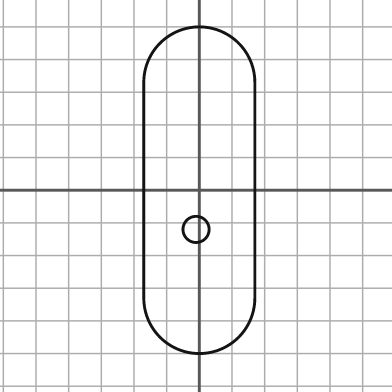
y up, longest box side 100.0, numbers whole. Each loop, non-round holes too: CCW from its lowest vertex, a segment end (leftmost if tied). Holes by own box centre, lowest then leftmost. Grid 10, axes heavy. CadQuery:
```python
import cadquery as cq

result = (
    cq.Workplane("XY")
    .moveTo(-17.0, -33.0)
    .threePointArc((0.0, -50.0), (17.0, -33.0))
    .lineTo(17.0, 33.0)
    .threePointArc((0.0, 50.0), (-17.0, 33.0))
    .close()
    .moveTo(-1.0, -12.0)
    .circle(4.0)
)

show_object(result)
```